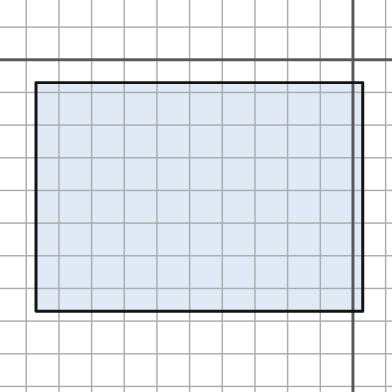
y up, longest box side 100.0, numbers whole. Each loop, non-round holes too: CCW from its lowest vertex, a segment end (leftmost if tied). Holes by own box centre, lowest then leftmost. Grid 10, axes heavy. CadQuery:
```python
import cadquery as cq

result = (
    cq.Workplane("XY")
    .moveTo(-97.0, -77.0)
    .lineTo(3.0, -77.0)
    .lineTo(3.0, -7.0)
    .lineTo(-97.0, -7.0)
    .close()
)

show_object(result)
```